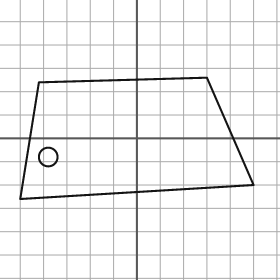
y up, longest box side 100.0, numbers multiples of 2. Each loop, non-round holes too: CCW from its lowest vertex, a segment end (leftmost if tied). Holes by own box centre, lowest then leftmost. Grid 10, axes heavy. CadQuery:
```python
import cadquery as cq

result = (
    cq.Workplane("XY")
    .moveTo(-50.0, -26.0)
    .lineTo(50.0, -20.0)
    .lineTo(30.0, 26.0)
    .lineTo(-42.0, 24.0)
    .close()
    .moveTo(-38.0, -8.0)
    .circle(4.0)
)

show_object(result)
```